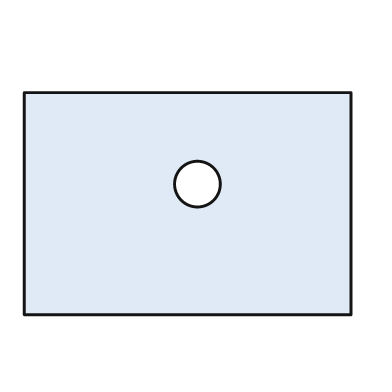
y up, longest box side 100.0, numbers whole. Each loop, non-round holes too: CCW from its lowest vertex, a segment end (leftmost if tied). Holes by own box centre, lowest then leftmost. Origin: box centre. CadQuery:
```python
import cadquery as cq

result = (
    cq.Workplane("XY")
    .moveTo(-50.0, -34.0)
    .lineTo(50.0, -34.0)
    .lineTo(50.0, 34.0)
    .lineTo(-50.0, 34.0)
    .close()
    .moveTo(3.0, 6.0)
    .circle(7.0)
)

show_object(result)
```